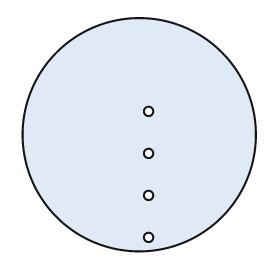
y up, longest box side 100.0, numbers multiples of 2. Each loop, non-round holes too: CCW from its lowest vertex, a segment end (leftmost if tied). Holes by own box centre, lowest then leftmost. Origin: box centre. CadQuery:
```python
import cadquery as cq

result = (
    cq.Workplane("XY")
    .moveTo(0.0, 0.0)
    .circle(50.0)
    .moveTo(4.0, -44.0)
    .circle(2.0)
    .moveTo(4.0, -26.0)
    .circle(2.0)
    .moveTo(4.0, -8.0)
    .circle(2.0)
    .moveTo(4.0, 10.0)
    .circle(2.0)
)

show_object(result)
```